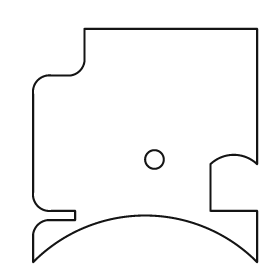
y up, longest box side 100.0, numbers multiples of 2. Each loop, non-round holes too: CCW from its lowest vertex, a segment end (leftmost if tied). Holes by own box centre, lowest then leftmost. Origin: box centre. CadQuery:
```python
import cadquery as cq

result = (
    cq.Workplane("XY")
    .moveTo(-48.0, -50.0)
    .threePointArc((0.0, -30.0), (48.0, -50.0))
    .lineTo(48.0, -28.0)
    .lineTo(28.0, -28.0)
    .lineTo(28.0, -8.0)
    .threePointArc((38.0, -4.0), (48.0, -8.0))
    .lineTo(48.0, 50.0)
    .lineTo(-26.0, 50.0)
    .lineTo(-26.0, 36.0)
    .threePointArc((-28.0, 32.0), (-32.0, 30.0))
    .lineTo(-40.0, 30.0)
    .threePointArc((-46.0, 28.0), (-48.0, 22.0))
    .lineTo(-48.0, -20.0)
    .threePointArc((-46.0, -26.0), (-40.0, -28.0))
    .lineTo(-30.0, -28.0)
    .lineTo(-30.0, -32.0)
    .lineTo(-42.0, -32.0)
    .threePointArc((-46.0, -34.0), (-48.0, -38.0))
    .close()
    .moveTo(4.0, -6.0)
    .circle(4.0)
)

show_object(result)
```